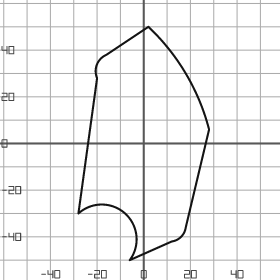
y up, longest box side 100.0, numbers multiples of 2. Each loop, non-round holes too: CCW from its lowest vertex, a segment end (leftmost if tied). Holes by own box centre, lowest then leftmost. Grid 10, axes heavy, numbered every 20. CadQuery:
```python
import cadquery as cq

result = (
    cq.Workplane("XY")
    .moveTo(-6.0, -50.0)
    .lineTo(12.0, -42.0)
    .threePointArc((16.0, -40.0), (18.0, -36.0))
    .lineTo(28.0, 6.0)
    .threePointArc((18.0, 30.0), (2.0, 50.0))
    .lineTo(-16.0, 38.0)
    .threePointArc((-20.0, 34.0), (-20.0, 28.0))
    .lineTo(-28.0, -30.0)
    .threePointArc((-8.0, -30.0), (-6.0, -50.0))
    .close()
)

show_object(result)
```